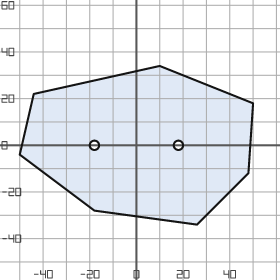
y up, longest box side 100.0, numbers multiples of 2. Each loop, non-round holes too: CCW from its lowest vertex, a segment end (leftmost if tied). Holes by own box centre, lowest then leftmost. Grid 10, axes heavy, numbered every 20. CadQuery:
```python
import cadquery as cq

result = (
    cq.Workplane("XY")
    .moveTo(26.0, -34.0)
    .lineTo(48.0, -12.0)
    .lineTo(50.0, 18.0)
    .lineTo(10.0, 34.0)
    .lineTo(-44.0, 22.0)
    .lineTo(-50.0, -4.0)
    .lineTo(-18.0, -28.0)
    .close()
    .moveTo(-18.0, 0.0)
    .circle(2.0)
    .moveTo(18.0, 0.0)
    .circle(2.0)
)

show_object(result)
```